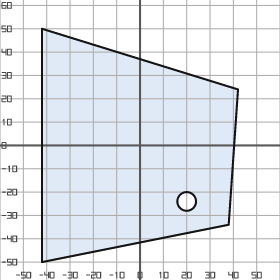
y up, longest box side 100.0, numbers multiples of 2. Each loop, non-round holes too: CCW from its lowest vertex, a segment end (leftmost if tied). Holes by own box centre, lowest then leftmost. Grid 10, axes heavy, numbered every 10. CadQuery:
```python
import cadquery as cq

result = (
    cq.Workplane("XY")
    .moveTo(-42.0, -50.0)
    .lineTo(38.0, -34.0)
    .lineTo(42.0, 24.0)
    .lineTo(-42.0, 50.0)
    .close()
    .moveTo(20.0, -24.0)
    .circle(4.0)
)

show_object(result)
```